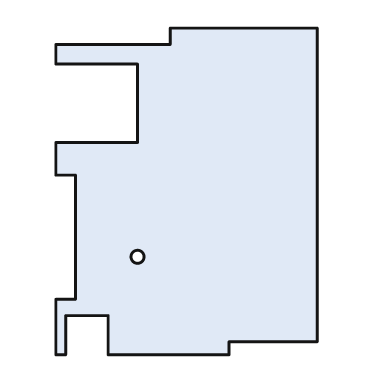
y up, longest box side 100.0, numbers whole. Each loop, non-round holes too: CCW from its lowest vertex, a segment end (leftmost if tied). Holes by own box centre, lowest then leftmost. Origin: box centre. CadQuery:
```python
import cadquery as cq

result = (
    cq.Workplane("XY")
    .moveTo(-40.0, -50.0)
    .lineTo(-37.0, -50.0)
    .lineTo(-37.0, -38.0)
    .lineTo(-24.0, -38.0)
    .lineTo(-24.0, -50.0)
    .lineTo(13.0, -50.0)
    .lineTo(13.0, -46.0)
    .lineTo(40.0, -46.0)
    .lineTo(40.0, 50.0)
    .lineTo(-5.0, 50.0)
    .lineTo(-5.0, 45.0)
    .lineTo(-40.0, 45.0)
    .lineTo(-40.0, 39.0)
    .lineTo(-15.0, 39.0)
    .lineTo(-15.0, 15.0)
    .lineTo(-40.0, 15.0)
    .lineTo(-40.0, 5.0)
    .lineTo(-34.0, 5.0)
    .lineTo(-34.0, -33.0)
    .lineTo(-40.0, -33.0)
    .close()
    .moveTo(-15.0, -20.0)
    .circle(2.0)
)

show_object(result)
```